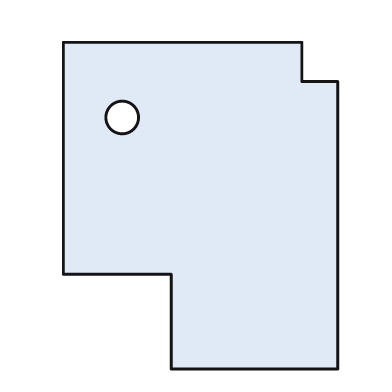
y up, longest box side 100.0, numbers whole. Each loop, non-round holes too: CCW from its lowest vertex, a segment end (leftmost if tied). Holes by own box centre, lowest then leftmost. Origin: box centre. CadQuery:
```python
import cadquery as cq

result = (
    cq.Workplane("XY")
    .moveTo(-9.0, -50.0)
    .lineTo(42.0, -50.0)
    .lineTo(42.0, 38.0)
    .lineTo(31.0, 38.0)
    .lineTo(31.0, 50.0)
    .lineTo(-42.0, 50.0)
    .lineTo(-42.0, -21.0)
    .lineTo(-9.0, -21.0)
    .close()
    .moveTo(-24.0, 27.0)
    .circle(5.0)
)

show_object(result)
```